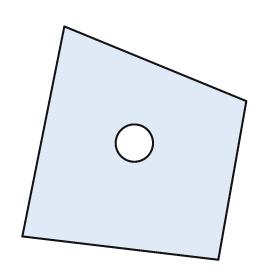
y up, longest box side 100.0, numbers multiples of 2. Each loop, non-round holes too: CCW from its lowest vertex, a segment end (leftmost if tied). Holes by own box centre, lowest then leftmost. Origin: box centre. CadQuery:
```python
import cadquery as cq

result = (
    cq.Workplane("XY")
    .moveTo(36.0, -50.0)
    .lineTo(48.0, 18.0)
    .lineTo(-30.0, 50.0)
    .lineTo(-48.0, -40.0)
    .close()
    .moveTo(0.0, 0.0)
    .circle(8.0)
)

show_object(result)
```